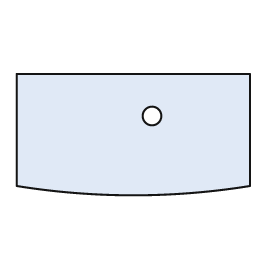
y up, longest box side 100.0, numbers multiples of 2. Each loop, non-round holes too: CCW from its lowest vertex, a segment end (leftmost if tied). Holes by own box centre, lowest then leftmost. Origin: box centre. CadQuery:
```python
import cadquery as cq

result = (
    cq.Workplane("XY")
    .moveTo(-50.0, -22.0)
    .threePointArc((0.0, -26.0), (50.0, -22.0))
    .lineTo(50.0, 26.0)
    .lineTo(-50.0, 26.0)
    .close()
    .moveTo(8.0, 8.0)
    .circle(4.0)
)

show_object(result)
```